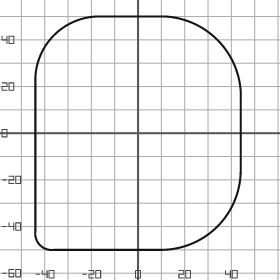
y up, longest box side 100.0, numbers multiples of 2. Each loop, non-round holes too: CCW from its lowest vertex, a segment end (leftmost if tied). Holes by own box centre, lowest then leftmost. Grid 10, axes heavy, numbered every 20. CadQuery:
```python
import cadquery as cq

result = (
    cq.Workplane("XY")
    .moveTo(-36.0, -50.0)
    .lineTo(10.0, -50.0)
    .threePointArc((34.0, -40.0), (44.0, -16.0))
    .lineTo(44.0, 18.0)
    .threePointArc((34.0, 40.0), (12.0, 50.0))
    .lineTo(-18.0, 50.0)
    .threePointArc((-36.0, 42.0), (-44.0, 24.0))
    .lineTo(-44.0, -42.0)
    .threePointArc((-42.0, -48.0), (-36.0, -50.0))
    .close()
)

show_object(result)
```